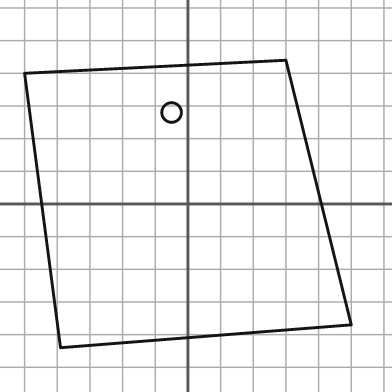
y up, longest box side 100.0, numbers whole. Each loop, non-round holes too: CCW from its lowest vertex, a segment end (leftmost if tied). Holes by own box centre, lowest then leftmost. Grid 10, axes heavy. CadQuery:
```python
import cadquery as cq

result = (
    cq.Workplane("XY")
    .moveTo(-39.0, -44.0)
    .lineTo(50.0, -37.0)
    .lineTo(30.0, 44.0)
    .lineTo(-50.0, 40.0)
    .close()
    .moveTo(-5.0, 28.0)
    .circle(3.0)
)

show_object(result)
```